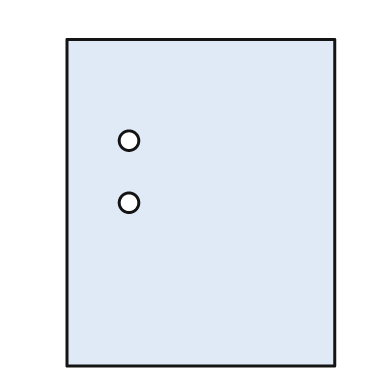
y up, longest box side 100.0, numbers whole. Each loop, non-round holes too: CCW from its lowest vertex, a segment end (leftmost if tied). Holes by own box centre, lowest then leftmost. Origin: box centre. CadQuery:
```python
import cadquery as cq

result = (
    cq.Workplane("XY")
    .moveTo(-41.0, -50.0)
    .lineTo(41.0, -50.0)
    .lineTo(41.0, 50.0)
    .lineTo(-41.0, 50.0)
    .close()
    .moveTo(-22.0, 0.0)
    .circle(3.0)
    .moveTo(-22.0, 19.0)
    .circle(3.0)
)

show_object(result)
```